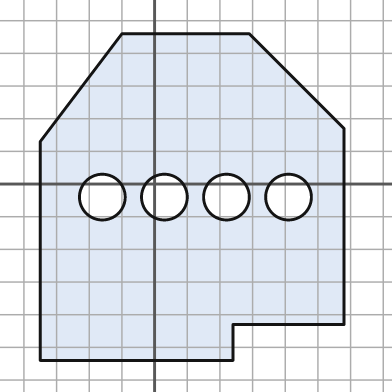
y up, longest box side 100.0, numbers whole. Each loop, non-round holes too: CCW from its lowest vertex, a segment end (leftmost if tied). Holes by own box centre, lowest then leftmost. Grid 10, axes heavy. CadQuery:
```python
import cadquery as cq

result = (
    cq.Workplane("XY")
    .moveTo(-35.0, -54.0)
    .lineTo(24.0, -54.0)
    .lineTo(24.0, -43.0)
    .lineTo(58.0, -43.0)
    .lineTo(58.0, 17.0)
    .lineTo(29.0, 46.0)
    .lineTo(-10.0, 46.0)
    .lineTo(-35.0, 13.0)
    .close()
    .moveTo(-16.0, -4.0)
    .circle(7.0)
    .moveTo(3.0, -4.0)
    .circle(7.0)
    .moveTo(22.0, -4.0)
    .circle(7.0)
    .moveTo(41.0, -4.0)
    .circle(7.0)
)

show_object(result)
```